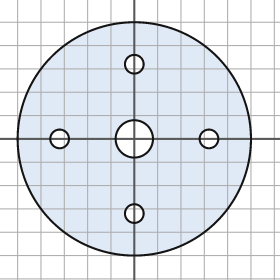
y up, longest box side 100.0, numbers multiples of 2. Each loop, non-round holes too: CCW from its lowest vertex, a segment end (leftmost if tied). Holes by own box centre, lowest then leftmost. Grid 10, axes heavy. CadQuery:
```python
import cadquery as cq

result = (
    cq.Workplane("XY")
    .moveTo(0.0, 0.0)
    .circle(50.0)
    .moveTo(0.0, -32.0)
    .circle(4.0)
    .moveTo(-32.0, 0.0)
    .circle(4.0)
    .moveTo(0.0, 0.0)
    .circle(8.0)
    .moveTo(32.0, 0.0)
    .circle(4.0)
    .moveTo(0.0, 32.0)
    .circle(4.0)
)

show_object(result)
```